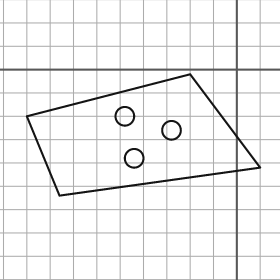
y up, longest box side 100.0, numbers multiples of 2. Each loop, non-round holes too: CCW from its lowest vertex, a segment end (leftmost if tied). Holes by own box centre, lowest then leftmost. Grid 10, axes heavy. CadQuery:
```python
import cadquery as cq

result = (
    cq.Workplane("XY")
    .moveTo(-76.0, -54.0)
    .lineTo(10.0, -42.0)
    .lineTo(-20.0, -2.0)
    .lineTo(-90.0, -20.0)
    .close()
    .moveTo(-44.0, -38.0)
    .circle(4.0)
    .moveTo(-28.0, -26.0)
    .circle(4.0)
    .moveTo(-48.0, -20.0)
    .circle(4.0)
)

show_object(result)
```